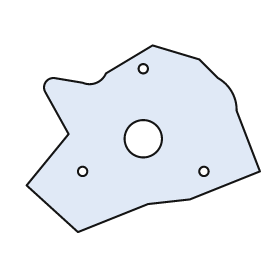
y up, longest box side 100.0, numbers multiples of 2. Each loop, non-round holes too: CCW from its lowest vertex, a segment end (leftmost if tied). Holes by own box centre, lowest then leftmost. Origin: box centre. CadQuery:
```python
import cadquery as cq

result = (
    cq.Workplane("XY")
    .moveTo(-28.0, -40.0)
    .lineTo(2.0, -28.0)
    .lineTo(20.0, -26.0)
    .lineTo(50.0, -14.0)
    .lineTo(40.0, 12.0)
    .threePointArc((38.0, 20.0), (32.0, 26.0))
    .lineTo(24.0, 34.0)
    .lineTo(4.0, 40.0)
    .lineTo(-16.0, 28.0)
    .threePointArc((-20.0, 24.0), (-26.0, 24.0))
    .lineTo(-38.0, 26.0)
    .threePointArc((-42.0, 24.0), (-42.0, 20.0))
    .lineTo(-32.0, 2.0)
    .lineTo(-50.0, -20.0)
    .close()
    .moveTo(-26.0, -14.0)
    .circle(2.0)
    .moveTo(26.0, -14.0)
    .circle(2.0)
    .moveTo(0.0, 0.0)
    .circle(8.0)
    .moveTo(0.0, 30.0)
    .circle(2.0)
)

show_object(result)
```